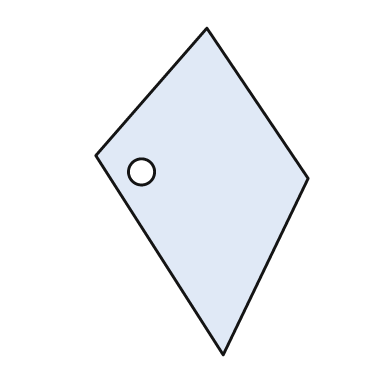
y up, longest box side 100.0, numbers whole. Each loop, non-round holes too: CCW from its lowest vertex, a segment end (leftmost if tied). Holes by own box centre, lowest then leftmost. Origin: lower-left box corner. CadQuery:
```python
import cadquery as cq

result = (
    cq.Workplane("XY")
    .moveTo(39.0, 0.0)
    .lineTo(65.0, 54.0)
    .lineTo(34.0, 100.0)
    .lineTo(0.0, 61.0)
    .close()
    .moveTo(14.0, 56.0)
    .circle(4.0)
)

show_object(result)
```